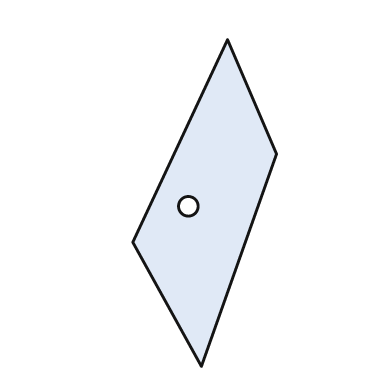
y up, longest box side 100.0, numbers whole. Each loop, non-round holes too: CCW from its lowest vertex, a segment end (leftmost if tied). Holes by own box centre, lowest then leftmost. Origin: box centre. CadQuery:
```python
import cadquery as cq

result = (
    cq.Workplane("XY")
    .moveTo(-1.0, -50.0)
    .lineTo(22.0, 15.0)
    .lineTo(7.0, 50.0)
    .lineTo(-22.0, -12.0)
    .close()
    .moveTo(-5.0, -1.0)
    .circle(3.0)
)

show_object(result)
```